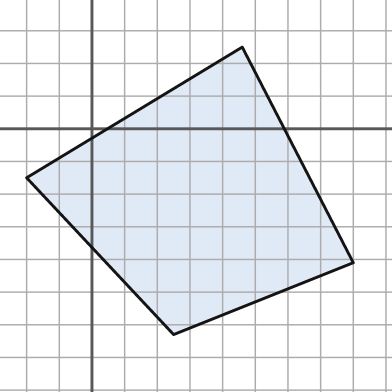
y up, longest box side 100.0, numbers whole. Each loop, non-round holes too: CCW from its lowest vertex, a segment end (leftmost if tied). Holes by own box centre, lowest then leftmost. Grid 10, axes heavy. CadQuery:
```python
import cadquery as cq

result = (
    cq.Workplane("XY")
    .moveTo(25.0, -63.0)
    .lineTo(80.0, -41.0)
    .lineTo(46.0, 25.0)
    .lineTo(-20.0, -15.0)
    .close()
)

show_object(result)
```